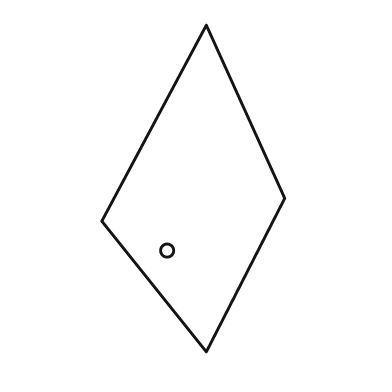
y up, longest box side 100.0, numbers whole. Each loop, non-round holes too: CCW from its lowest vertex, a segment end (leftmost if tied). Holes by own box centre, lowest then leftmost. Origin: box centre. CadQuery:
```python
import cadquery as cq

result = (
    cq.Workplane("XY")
    .moveTo(4.0, -50.0)
    .lineTo(28.0, -3.0)
    .lineTo(4.0, 50.0)
    .lineTo(-28.0, -10.0)
    .close()
    .moveTo(-8.0, -19.0)
    .circle(2.0)
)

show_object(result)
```